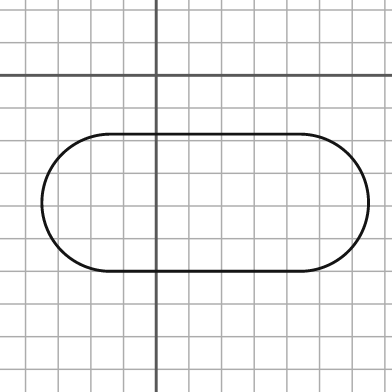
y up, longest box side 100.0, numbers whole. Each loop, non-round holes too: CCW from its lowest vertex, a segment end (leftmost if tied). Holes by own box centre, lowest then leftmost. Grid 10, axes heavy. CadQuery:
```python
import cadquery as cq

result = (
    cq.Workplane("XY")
    .moveTo(-14.0, -60.0)
    .lineTo(44.0, -60.0)
    .threePointArc((65.0, -39.0), (44.0, -18.0))
    .lineTo(-14.0, -18.0)
    .threePointArc((-35.0, -39.0), (-14.0, -60.0))
    .close()
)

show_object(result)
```